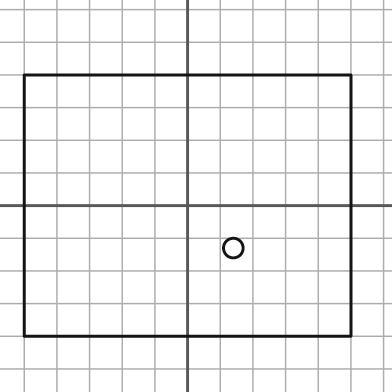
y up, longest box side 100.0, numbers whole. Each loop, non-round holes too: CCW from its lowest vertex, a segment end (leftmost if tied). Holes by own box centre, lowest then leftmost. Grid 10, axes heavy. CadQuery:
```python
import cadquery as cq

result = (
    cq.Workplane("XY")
    .moveTo(-50.0, -40.0)
    .lineTo(50.0, -40.0)
    .lineTo(50.0, 40.0)
    .lineTo(-50.0, 40.0)
    .close()
    .moveTo(14.0, -13.0)
    .circle(3.0)
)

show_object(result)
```